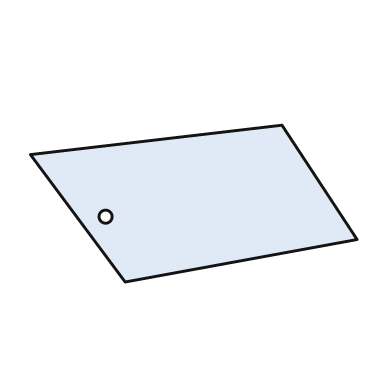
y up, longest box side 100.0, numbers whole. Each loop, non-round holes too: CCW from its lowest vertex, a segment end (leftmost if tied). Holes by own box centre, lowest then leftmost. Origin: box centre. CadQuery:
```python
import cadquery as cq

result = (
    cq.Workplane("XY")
    .moveTo(-21.0, -24.0)
    .lineTo(50.0, -11.0)
    .lineTo(27.0, 24.0)
    .lineTo(-50.0, 15.0)
    .close()
    .moveTo(-27.0, -4.0)
    .circle(2.0)
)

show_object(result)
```